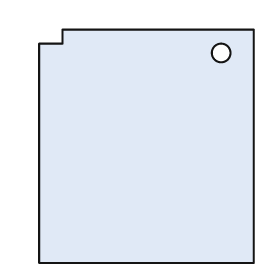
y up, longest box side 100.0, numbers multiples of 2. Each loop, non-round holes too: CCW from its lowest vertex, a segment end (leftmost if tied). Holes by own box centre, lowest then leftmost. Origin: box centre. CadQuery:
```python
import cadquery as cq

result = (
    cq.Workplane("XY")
    .moveTo(-46.0, -50.0)
    .lineTo(46.0, -50.0)
    .lineTo(46.0, 50.0)
    .lineTo(-36.0, 50.0)
    .lineTo(-36.0, 44.0)
    .lineTo(-46.0, 44.0)
    .close()
    .moveTo(32.0, 40.0)
    .circle(4.0)
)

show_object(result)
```